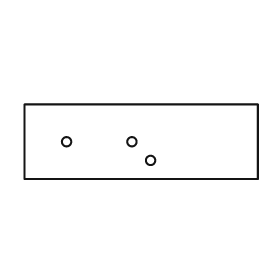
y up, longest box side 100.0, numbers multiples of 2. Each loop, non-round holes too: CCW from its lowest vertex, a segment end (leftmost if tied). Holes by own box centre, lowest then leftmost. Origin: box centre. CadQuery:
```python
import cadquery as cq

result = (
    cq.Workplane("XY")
    .moveTo(-50.0, -16.0)
    .lineTo(50.0, -16.0)
    .lineTo(50.0, 16.0)
    .lineTo(-50.0, 16.0)
    .close()
    .moveTo(4.0, -8.0)
    .circle(2.0)
    .moveTo(-32.0, 0.0)
    .circle(2.0)
    .moveTo(-4.0, 0.0)
    .circle(2.0)
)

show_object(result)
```